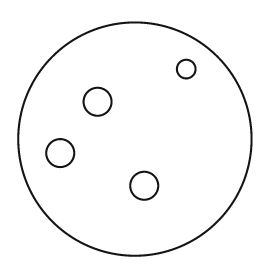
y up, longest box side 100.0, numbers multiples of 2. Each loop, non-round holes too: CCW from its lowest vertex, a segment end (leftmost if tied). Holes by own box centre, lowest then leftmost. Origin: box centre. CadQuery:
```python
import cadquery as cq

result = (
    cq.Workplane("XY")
    .moveTo(0.0, 0.0)
    .circle(50.0)
    .moveTo(4.0, -20.0)
    .circle(6.0)
    .moveTo(-32.0, -6.0)
    .circle(6.0)
    .moveTo(-16.0, 16.0)
    .circle(6.0)
    .moveTo(22.0, 30.0)
    .circle(4.0)
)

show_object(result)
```